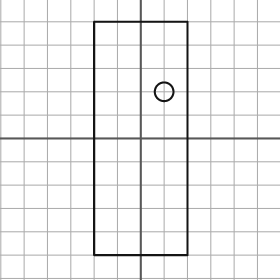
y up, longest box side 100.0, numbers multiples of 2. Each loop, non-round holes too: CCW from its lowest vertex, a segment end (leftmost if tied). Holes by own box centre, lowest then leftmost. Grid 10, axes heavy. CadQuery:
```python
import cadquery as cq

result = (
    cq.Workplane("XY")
    .moveTo(-20.0, -50.0)
    .lineTo(20.0, -50.0)
    .lineTo(20.0, 50.0)
    .lineTo(-20.0, 50.0)
    .close()
    .moveTo(10.0, 20.0)
    .circle(4.0)
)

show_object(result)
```